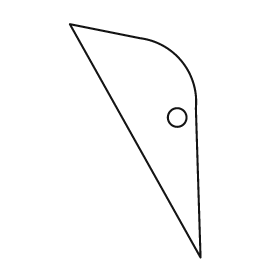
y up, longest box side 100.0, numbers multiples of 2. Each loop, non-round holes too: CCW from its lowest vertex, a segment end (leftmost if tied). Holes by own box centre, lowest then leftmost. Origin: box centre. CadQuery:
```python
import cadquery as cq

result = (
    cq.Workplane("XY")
    .moveTo(28.0, -50.0)
    .lineTo(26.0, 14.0)
    .threePointArc((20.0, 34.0), (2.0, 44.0))
    .lineTo(-28.0, 50.0)
    .close()
    .moveTo(18.0, 10.0)
    .circle(4.0)
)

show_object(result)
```